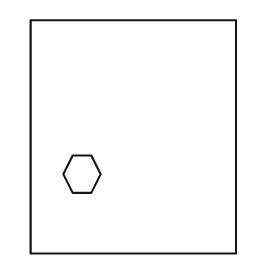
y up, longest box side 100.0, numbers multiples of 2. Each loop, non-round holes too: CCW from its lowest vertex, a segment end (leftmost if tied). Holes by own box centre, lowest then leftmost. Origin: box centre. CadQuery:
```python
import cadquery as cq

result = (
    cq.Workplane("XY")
    .moveTo(-44.0, -50.0)
    .lineTo(44.0, -50.0)
    .lineTo(44.0, 50.0)
    .lineTo(-44.0, 50.0)
    .close()
    .moveTo(-26.0, -24.0)
    .lineTo(-18.0, -24.0)
    .lineTo(-14.0, -16.0)
    .lineTo(-18.0, -8.0)
    .lineTo(-26.0, -8.0)
    .lineTo(-30.0, -16.0)
    .close()
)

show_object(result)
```